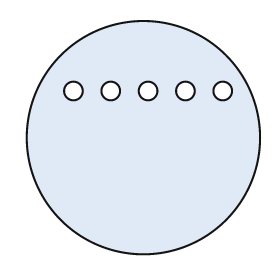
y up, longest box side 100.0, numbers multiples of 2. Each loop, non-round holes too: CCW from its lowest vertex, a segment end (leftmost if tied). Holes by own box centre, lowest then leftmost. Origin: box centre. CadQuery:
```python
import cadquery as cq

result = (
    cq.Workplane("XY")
    .moveTo(0.0, 0.0)
    .circle(50.0)
    .moveTo(-30.0, 20.0)
    .circle(4.0)
    .moveTo(-14.0, 20.0)
    .circle(4.0)
    .moveTo(2.0, 20.0)
    .circle(4.0)
    .moveTo(18.0, 20.0)
    .circle(4.0)
    .moveTo(34.0, 20.0)
    .circle(4.0)
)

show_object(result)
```